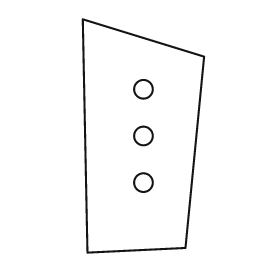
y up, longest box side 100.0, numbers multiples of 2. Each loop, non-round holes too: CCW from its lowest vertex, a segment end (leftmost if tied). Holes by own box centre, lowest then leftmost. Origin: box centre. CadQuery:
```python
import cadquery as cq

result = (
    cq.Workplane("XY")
    .moveTo(-24.0, -50.0)
    .lineTo(18.0, -48.0)
    .lineTo(26.0, 34.0)
    .lineTo(-26.0, 50.0)
    .close()
    .moveTo(0.0, -20.0)
    .circle(4.0)
    .moveTo(0.0, 0.0)
    .circle(4.0)
    .moveTo(0.0, 20.0)
    .circle(4.0)
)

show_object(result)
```